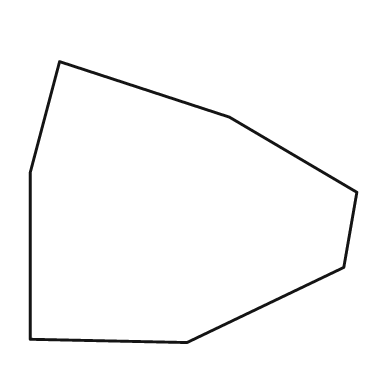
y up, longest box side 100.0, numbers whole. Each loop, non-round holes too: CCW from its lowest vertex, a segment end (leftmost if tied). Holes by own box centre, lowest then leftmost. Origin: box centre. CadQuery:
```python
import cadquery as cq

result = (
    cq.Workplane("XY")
    .moveTo(-2.0, -43.0)
    .lineTo(46.0, -20.0)
    .lineTo(50.0, 3.0)
    .lineTo(11.0, 26.0)
    .lineTo(-41.0, 43.0)
    .lineTo(-50.0, 9.0)
    .lineTo(-50.0, -42.0)
    .close()
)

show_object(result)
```